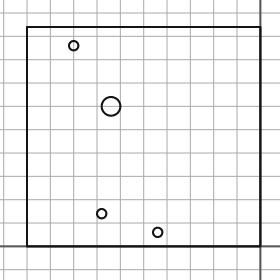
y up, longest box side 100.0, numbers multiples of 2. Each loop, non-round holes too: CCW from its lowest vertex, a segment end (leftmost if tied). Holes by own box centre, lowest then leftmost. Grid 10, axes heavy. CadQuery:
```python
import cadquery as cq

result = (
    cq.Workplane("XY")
    .moveTo(-100.0, 0.0)
    .lineTo(0.0, 0.0)
    .lineTo(0.0, 94.0)
    .lineTo(-100.0, 94.0)
    .close()
    .moveTo(-44.0, 6.0)
    .circle(2.0)
    .moveTo(-68.0, 14.0)
    .circle(2.0)
    .moveTo(-64.0, 60.0)
    .circle(4.0)
    .moveTo(-80.0, 86.0)
    .circle(2.0)
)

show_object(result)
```